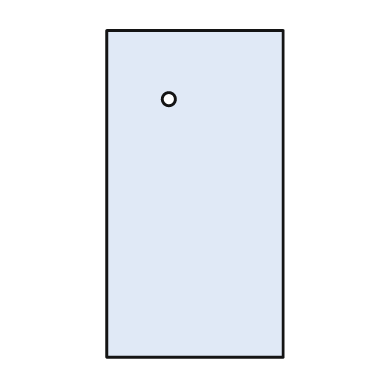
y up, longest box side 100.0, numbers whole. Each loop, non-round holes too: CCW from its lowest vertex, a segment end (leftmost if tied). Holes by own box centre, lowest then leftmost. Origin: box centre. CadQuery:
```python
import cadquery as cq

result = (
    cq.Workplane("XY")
    .moveTo(-27.0, -50.0)
    .lineTo(27.0, -50.0)
    .lineTo(27.0, 50.0)
    .lineTo(-27.0, 50.0)
    .close()
    .moveTo(-8.0, 29.0)
    .circle(2.0)
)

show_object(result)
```